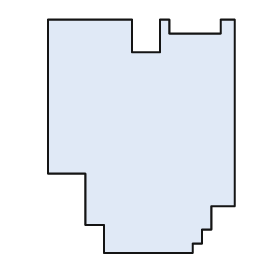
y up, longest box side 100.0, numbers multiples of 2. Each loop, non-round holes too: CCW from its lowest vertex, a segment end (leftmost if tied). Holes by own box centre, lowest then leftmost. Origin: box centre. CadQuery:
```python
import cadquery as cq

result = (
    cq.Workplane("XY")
    .moveTo(-16.0, -50.0)
    .lineTo(22.0, -50.0)
    .lineTo(22.0, -46.0)
    .lineTo(26.0, -46.0)
    .lineTo(26.0, -40.0)
    .lineTo(30.0, -40.0)
    .lineTo(30.0, -30.0)
    .lineTo(40.0, -30.0)
    .lineTo(40.0, 50.0)
    .lineTo(34.0, 50.0)
    .lineTo(34.0, 44.0)
    .lineTo(12.0, 44.0)
    .lineTo(12.0, 50.0)
    .lineTo(8.0, 50.0)
    .lineTo(8.0, 36.0)
    .lineTo(-4.0, 36.0)
    .lineTo(-4.0, 50.0)
    .lineTo(-40.0, 50.0)
    .lineTo(-40.0, -16.0)
    .lineTo(-24.0, -16.0)
    .lineTo(-24.0, -38.0)
    .lineTo(-16.0, -38.0)
    .close()
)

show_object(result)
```